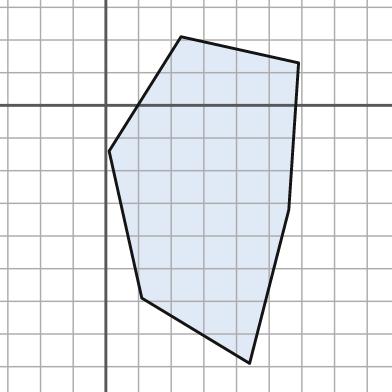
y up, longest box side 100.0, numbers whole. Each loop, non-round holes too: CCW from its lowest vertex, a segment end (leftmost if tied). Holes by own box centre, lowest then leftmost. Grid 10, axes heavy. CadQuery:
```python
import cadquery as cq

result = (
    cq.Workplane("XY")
    .moveTo(44.0, -79.0)
    .lineTo(56.0, -32.0)
    .lineTo(59.0, 13.0)
    .lineTo(23.0, 21.0)
    .lineTo(1.0, -14.0)
    .lineTo(11.0, -59.0)
    .close()
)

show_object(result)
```